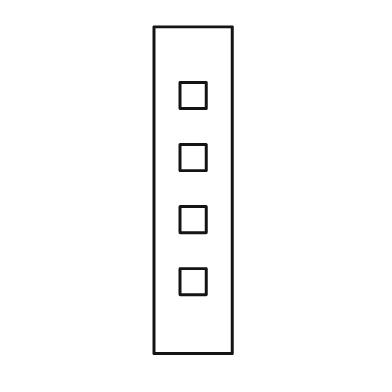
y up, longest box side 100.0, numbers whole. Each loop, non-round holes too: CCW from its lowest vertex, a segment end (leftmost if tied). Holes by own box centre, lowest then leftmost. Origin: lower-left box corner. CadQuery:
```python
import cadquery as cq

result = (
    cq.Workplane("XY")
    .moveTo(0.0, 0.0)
    .lineTo(24.0, 0.0)
    .lineTo(24.0, 100.0)
    .lineTo(0.0, 100.0)
    .close()
    .moveTo(8.0, 18.0)
    .lineTo(16.0, 18.0)
    .lineTo(16.0, 26.0)
    .lineTo(8.0, 26.0)
    .close()
    .moveTo(8.0, 37.0)
    .lineTo(16.0, 37.0)
    .lineTo(16.0, 45.0)
    .lineTo(8.0, 45.0)
    .close()
    .moveTo(8.0, 56.0)
    .lineTo(16.0, 56.0)
    .lineTo(16.0, 64.0)
    .lineTo(8.0, 64.0)
    .close()
    .moveTo(8.0, 75.0)
    .lineTo(16.0, 75.0)
    .lineTo(16.0, 83.0)
    .lineTo(8.0, 83.0)
    .close()
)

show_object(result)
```